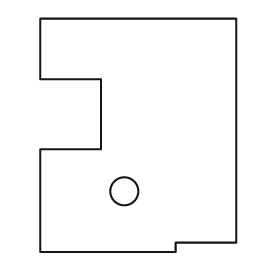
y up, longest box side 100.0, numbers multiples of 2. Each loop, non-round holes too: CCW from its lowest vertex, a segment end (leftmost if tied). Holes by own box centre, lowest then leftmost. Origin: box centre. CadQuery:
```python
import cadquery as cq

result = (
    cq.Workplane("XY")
    .moveTo(-42.0, -50.0)
    .lineTo(16.0, -50.0)
    .lineTo(16.0, -46.0)
    .lineTo(42.0, -46.0)
    .lineTo(42.0, 50.0)
    .lineTo(-42.0, 50.0)
    .lineTo(-42.0, 24.0)
    .lineTo(-16.0, 24.0)
    .lineTo(-16.0, -6.0)
    .lineTo(-42.0, -6.0)
    .close()
    .moveTo(-6.0, -24.0)
    .circle(6.0)
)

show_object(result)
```